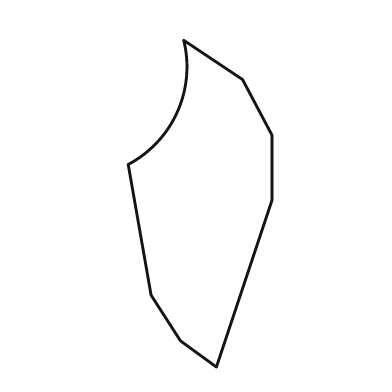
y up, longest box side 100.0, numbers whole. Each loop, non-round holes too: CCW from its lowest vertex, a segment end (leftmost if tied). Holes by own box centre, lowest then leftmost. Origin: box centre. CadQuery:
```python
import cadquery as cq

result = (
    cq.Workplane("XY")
    .moveTo(5.0, -50.0)
    .lineTo(22.0, 1.0)
    .lineTo(22.0, 21.0)
    .lineTo(13.0, 38.0)
    .lineTo(-5.0, 50.0)
    .threePointArc((-7.0, 28.0), (-22.0, 12.0))
    .lineTo(-15.0, -28.0)
    .lineTo(-6.0, -42.0)
    .close()
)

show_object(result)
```